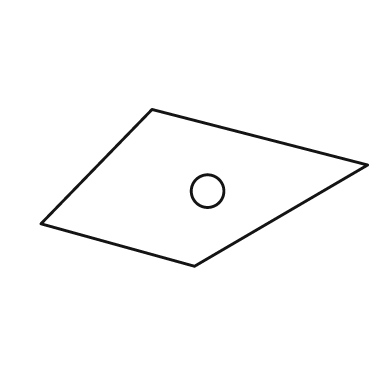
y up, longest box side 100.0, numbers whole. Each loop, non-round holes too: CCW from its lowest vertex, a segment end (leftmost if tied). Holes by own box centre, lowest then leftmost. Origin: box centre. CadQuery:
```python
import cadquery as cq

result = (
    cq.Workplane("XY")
    .moveTo(-3.0, -24.0)
    .lineTo(50.0, 7.0)
    .lineTo(-16.0, 24.0)
    .lineTo(-50.0, -11.0)
    .close()
    .moveTo(1.0, -1.0)
    .circle(5.0)
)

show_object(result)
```